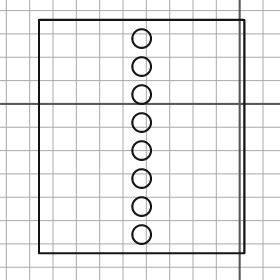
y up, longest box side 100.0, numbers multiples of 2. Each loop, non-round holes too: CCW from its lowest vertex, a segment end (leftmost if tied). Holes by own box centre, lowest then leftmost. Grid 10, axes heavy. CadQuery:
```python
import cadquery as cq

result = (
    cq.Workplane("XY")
    .moveTo(-86.0, -64.0)
    .lineTo(2.0, -64.0)
    .lineTo(2.0, 36.0)
    .lineTo(-86.0, 36.0)
    .close()
    .moveTo(-42.0, -56.0)
    .circle(4.0)
    .moveTo(-42.0, -44.0)
    .circle(4.0)
    .moveTo(-42.0, -32.0)
    .circle(4.0)
    .moveTo(-42.0, -20.0)
    .circle(4.0)
    .moveTo(-42.0, -8.0)
    .circle(4.0)
    .moveTo(-42.0, 4.0)
    .circle(4.0)
    .moveTo(-42.0, 16.0)
    .circle(4.0)
    .moveTo(-42.0, 28.0)
    .circle(4.0)
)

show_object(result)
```